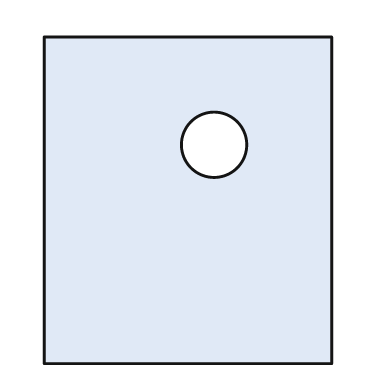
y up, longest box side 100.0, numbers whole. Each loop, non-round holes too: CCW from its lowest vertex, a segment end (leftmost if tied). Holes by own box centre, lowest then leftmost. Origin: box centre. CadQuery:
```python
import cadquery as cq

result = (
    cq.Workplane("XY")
    .moveTo(-44.0, -50.0)
    .lineTo(44.0, -50.0)
    .lineTo(44.0, 50.0)
    .lineTo(-44.0, 50.0)
    .close()
    .moveTo(8.0, 17.0)
    .circle(10.0)
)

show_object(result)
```